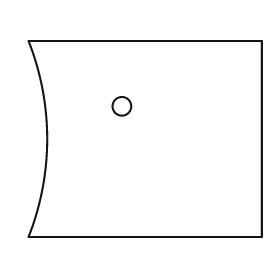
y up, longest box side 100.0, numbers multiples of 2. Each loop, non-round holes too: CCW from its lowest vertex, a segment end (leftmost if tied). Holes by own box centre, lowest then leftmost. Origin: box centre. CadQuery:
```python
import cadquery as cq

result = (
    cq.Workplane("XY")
    .moveTo(-50.0, -42.0)
    .lineTo(50.0, -42.0)
    .lineTo(50.0, 42.0)
    .lineTo(-50.0, 42.0)
    .threePointArc((-42.0, 0.0), (-50.0, -42.0))
    .close()
    .moveTo(-10.0, 14.0)
    .circle(4.0)
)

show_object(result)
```